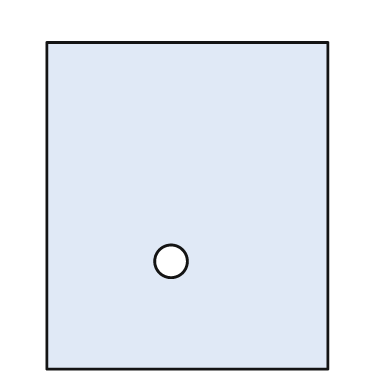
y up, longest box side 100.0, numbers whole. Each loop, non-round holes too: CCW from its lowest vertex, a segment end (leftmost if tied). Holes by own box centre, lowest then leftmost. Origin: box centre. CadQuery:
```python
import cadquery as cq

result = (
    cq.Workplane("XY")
    .moveTo(-43.0, -50.0)
    .lineTo(43.0, -50.0)
    .lineTo(43.0, 50.0)
    .lineTo(-43.0, 50.0)
    .close()
    .moveTo(-5.0, -17.0)
    .circle(5.0)
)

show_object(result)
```